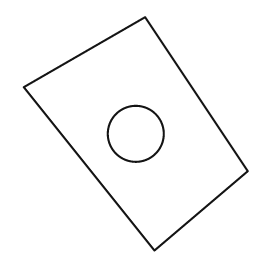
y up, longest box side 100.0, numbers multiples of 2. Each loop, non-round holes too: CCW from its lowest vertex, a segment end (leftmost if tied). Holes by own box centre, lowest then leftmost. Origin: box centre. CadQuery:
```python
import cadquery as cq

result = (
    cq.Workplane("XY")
    .moveTo(8.0, -50.0)
    .lineTo(48.0, -16.0)
    .lineTo(4.0, 50.0)
    .lineTo(-48.0, 20.0)
    .close()
    .moveTo(0.0, 0.0)
    .circle(12.0)
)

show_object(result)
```